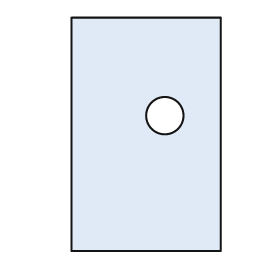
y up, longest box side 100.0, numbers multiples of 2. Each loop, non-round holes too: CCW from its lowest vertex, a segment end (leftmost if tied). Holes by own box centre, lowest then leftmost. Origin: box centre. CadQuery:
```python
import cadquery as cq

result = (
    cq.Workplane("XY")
    .moveTo(-32.0, -50.0)
    .lineTo(32.0, -50.0)
    .lineTo(32.0, 50.0)
    .lineTo(-32.0, 50.0)
    .close()
    .moveTo(8.0, 8.0)
    .circle(8.0)
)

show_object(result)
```